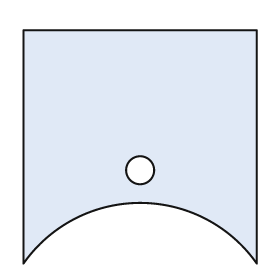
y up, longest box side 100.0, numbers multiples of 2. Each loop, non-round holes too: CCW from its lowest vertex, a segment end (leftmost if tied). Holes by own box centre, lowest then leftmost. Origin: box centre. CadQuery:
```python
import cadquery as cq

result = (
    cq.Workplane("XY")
    .moveTo(-50.0, -50.0)
    .threePointArc((0.0, -24.0), (50.0, -50.0))
    .lineTo(50.0, 50.0)
    .lineTo(-50.0, 50.0)
    .close()
    .moveTo(0.0, -10.0)
    .circle(6.0)
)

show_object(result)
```